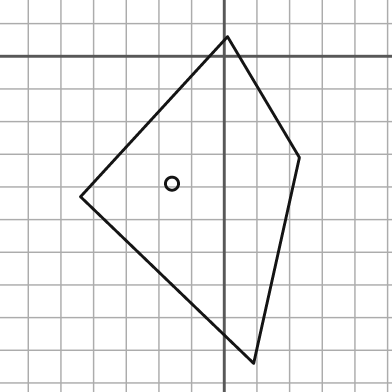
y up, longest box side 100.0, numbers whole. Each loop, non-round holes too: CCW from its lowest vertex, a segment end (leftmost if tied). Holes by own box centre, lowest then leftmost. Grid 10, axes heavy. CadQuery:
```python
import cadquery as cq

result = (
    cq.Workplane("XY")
    .moveTo(9.0, -94.0)
    .lineTo(23.0, -31.0)
    .lineTo(1.0, 6.0)
    .lineTo(-44.0, -43.0)
    .close()
    .moveTo(-16.0, -39.0)
    .circle(2.0)
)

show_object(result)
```